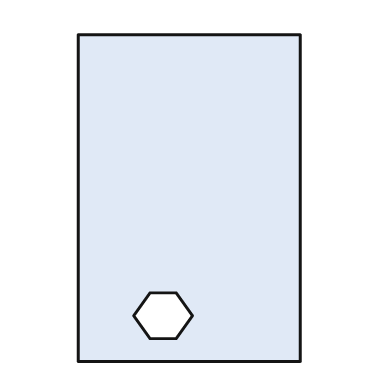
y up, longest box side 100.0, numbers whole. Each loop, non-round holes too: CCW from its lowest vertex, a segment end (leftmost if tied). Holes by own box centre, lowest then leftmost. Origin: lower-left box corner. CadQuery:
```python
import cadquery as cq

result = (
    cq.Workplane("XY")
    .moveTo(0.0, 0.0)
    .lineTo(68.0, 0.0)
    .lineTo(68.0, 100.0)
    .lineTo(0.0, 100.0)
    .close()
    .moveTo(22.0, 7.0)
    .lineTo(30.0, 7.0)
    .lineTo(35.0, 14.0)
    .lineTo(30.0, 21.0)
    .lineTo(22.0, 21.0)
    .lineTo(17.0, 14.0)
    .close()
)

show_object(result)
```